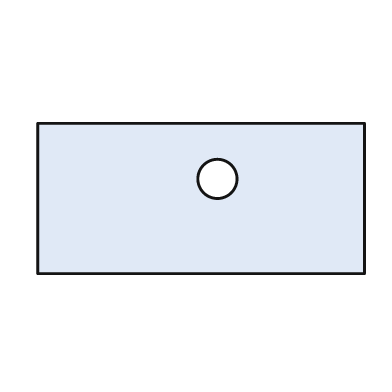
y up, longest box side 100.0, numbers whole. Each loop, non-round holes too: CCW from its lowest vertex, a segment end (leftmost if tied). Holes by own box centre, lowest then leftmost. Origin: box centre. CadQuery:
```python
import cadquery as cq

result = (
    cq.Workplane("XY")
    .moveTo(-50.0, -23.0)
    .lineTo(50.0, -23.0)
    .lineTo(50.0, 23.0)
    .lineTo(-50.0, 23.0)
    .close()
    .moveTo(5.0, 6.0)
    .circle(6.0)
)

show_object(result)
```